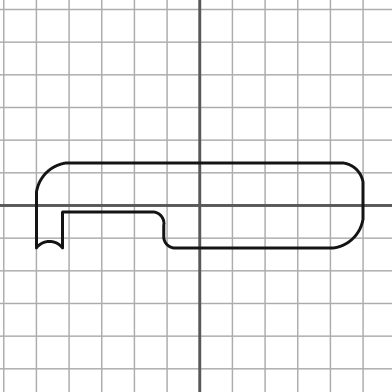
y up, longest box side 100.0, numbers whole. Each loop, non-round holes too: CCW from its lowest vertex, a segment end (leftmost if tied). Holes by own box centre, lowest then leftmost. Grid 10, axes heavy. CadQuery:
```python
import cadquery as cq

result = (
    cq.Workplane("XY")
    .moveTo(-50.0, -13.0)
    .threePointArc((-46.0, -11.0), (-42.0, -13.0))
    .lineTo(-42.0, -2.0)
    .lineTo(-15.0, -2.0)
    .threePointArc((-12.0, -3.0), (-11.0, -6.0))
    .lineTo(-11.0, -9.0)
    .threePointArc((-10.0, -12.0), (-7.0, -13.0))
    .lineTo(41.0, -13.0)
    .threePointArc((47.0, -10.0), (50.0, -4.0))
    .lineTo(50.0, 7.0)
    .threePointArc((48.0, 11.0), (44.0, 13.0))
    .lineTo(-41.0, 13.0)
    .threePointArc((-47.0, 10.0), (-50.0, 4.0))
    .close()
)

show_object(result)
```